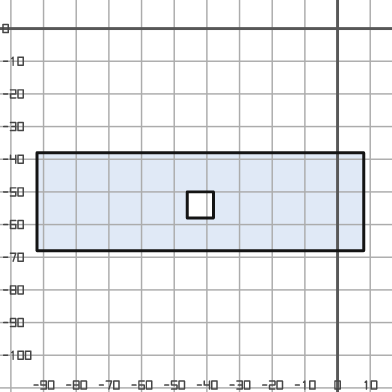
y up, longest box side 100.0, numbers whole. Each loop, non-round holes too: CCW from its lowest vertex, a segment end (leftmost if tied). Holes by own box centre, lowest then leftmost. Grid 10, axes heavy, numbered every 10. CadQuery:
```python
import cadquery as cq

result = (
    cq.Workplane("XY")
    .moveTo(-92.0, -68.0)
    .lineTo(8.0, -68.0)
    .lineTo(8.0, -38.0)
    .lineTo(-92.0, -38.0)
    .close()
    .moveTo(-46.0, -58.0)
    .lineTo(-38.0, -58.0)
    .lineTo(-38.0, -50.0)
    .lineTo(-46.0, -50.0)
    .close()
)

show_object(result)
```